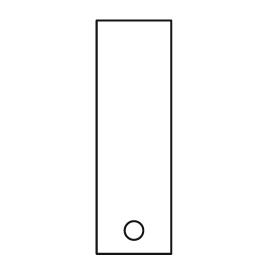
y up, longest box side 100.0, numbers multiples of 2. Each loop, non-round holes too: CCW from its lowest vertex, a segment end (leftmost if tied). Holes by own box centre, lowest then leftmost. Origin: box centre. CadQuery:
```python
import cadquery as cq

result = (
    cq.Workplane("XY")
    .moveTo(-16.0, -50.0)
    .lineTo(16.0, -50.0)
    .lineTo(16.0, 50.0)
    .lineTo(-16.0, 50.0)
    .close()
    .moveTo(0.0, -40.0)
    .circle(4.0)
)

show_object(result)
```